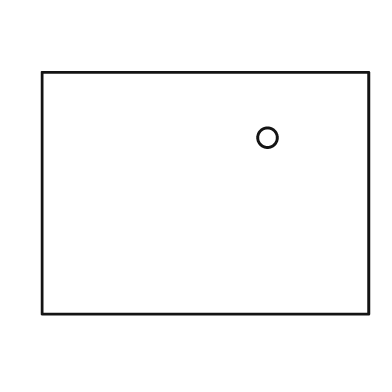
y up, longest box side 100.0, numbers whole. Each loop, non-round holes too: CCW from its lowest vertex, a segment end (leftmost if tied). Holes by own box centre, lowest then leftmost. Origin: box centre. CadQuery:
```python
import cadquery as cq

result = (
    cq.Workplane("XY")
    .moveTo(-50.0, -37.0)
    .lineTo(50.0, -37.0)
    .lineTo(50.0, 37.0)
    .lineTo(-50.0, 37.0)
    .close()
    .moveTo(19.0, 17.0)
    .circle(3.0)
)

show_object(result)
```